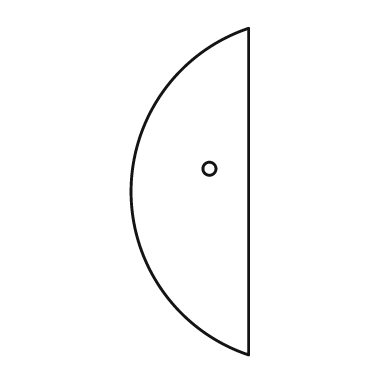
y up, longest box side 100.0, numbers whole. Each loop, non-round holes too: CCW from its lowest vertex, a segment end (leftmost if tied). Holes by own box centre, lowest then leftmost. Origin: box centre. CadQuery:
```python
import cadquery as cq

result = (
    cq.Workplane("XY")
    .moveTo(18.0, -50.0)
    .lineTo(18.0, 50.0)
    .threePointArc((-18.0, 0.0), (18.0, -50.0))
    .close()
    .moveTo(6.0, 7.0)
    .circle(2.0)
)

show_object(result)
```